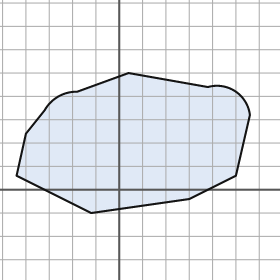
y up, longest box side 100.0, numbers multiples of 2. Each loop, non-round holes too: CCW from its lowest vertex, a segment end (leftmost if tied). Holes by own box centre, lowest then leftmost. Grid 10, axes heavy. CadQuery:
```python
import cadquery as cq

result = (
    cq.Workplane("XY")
    .moveTo(-12.0, -10.0)
    .lineTo(30.0, -4.0)
    .lineTo(50.0, 6.0)
    .lineTo(56.0, 32.0)
    .threePointArc((50.0, 42.0), (38.0, 44.0))
    .lineTo(4.0, 50.0)
    .lineTo(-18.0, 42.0)
    .threePointArc((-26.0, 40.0), (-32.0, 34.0))
    .lineTo(-40.0, 24.0)
    .lineTo(-44.0, 6.0)
    .close()
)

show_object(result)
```